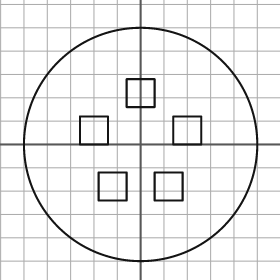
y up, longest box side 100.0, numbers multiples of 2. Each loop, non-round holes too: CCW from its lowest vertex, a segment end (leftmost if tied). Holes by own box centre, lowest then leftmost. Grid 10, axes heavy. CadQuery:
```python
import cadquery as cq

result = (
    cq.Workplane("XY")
    .moveTo(0.0, 0.0)
    .circle(50.0)
    .moveTo(-18.0, -24.0)
    .lineTo(-6.0, -24.0)
    .lineTo(-6.0, -12.0)
    .lineTo(-18.0, -12.0)
    .close()
    .moveTo(6.0, -24.0)
    .lineTo(18.0, -24.0)
    .lineTo(18.0, -12.0)
    .lineTo(6.0, -12.0)
    .close()
    .moveTo(-26.0, 0.0)
    .lineTo(-14.0, 0.0)
    .lineTo(-14.0, 12.0)
    .lineTo(-26.0, 12.0)
    .close()
    .moveTo(14.0, 0.0)
    .lineTo(26.0, 0.0)
    .lineTo(26.0, 12.0)
    .lineTo(14.0, 12.0)
    .close()
    .moveTo(-6.0, 16.0)
    .lineTo(6.0, 16.0)
    .lineTo(6.0, 28.0)
    .lineTo(-6.0, 28.0)
    .close()
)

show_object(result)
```